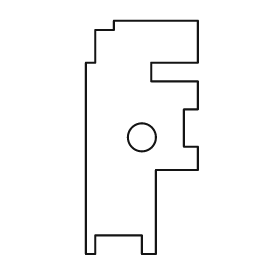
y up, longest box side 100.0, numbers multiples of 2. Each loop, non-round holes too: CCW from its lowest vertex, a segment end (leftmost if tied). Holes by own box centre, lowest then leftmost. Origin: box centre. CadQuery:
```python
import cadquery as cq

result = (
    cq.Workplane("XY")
    .moveTo(-24.0, -50.0)
    .lineTo(-20.0, -50.0)
    .lineTo(-20.0, -42.0)
    .lineTo(0.0, -42.0)
    .lineTo(0.0, -50.0)
    .lineTo(6.0, -50.0)
    .lineTo(6.0, -14.0)
    .lineTo(24.0, -14.0)
    .lineTo(24.0, -4.0)
    .lineTo(18.0, -4.0)
    .lineTo(18.0, 12.0)
    .lineTo(24.0, 12.0)
    .lineTo(24.0, 24.0)
    .lineTo(4.0, 24.0)
    .lineTo(4.0, 32.0)
    .lineTo(24.0, 32.0)
    .lineTo(24.0, 50.0)
    .lineTo(-12.0, 50.0)
    .lineTo(-12.0, 46.0)
    .lineTo(-20.0, 46.0)
    .lineTo(-20.0, 32.0)
    .lineTo(-24.0, 32.0)
    .close()
    .moveTo(0.0, 0.0)
    .circle(6.0)
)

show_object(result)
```